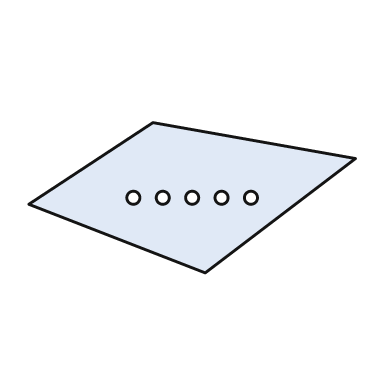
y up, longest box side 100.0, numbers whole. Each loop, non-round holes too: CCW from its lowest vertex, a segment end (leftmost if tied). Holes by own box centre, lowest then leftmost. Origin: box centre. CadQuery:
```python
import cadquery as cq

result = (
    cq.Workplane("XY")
    .moveTo(4.0, -23.0)
    .lineTo(50.0, 12.0)
    .lineTo(-12.0, 23.0)
    .lineTo(-50.0, -2.0)
    .close()
    .moveTo(-18.0, 0.0)
    .circle(2.0)
    .moveTo(-9.0, 0.0)
    .circle(2.0)
    .moveTo(0.0, 0.0)
    .circle(2.0)
    .moveTo(9.0, 0.0)
    .circle(2.0)
    .moveTo(18.0, 0.0)
    .circle(2.0)
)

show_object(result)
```